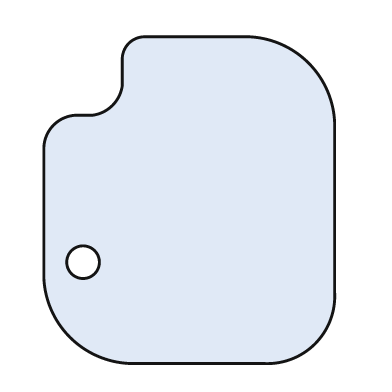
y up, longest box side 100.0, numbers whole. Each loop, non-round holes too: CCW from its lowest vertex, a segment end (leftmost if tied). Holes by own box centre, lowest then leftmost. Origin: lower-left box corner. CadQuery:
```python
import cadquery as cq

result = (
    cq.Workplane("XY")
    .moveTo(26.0, 0.0)
    .lineTo(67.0, 0.0)
    .threePointArc((83.0, 6.0), (89.0, 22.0))
    .lineTo(89.0, 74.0)
    .threePointArc((81.0, 92.0), (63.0, 100.0))
    .lineTo(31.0, 100.0)
    .threePointArc((26.0, 98.0), (24.0, 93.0))
    .lineTo(24.0, 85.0)
    .threePointArc((21.0, 79.0), (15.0, 76.0))
    .lineTo(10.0, 76.0)
    .threePointArc((3.0, 73.0), (0.0, 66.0))
    .lineTo(0.0, 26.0)
    .threePointArc((8.0, 8.0), (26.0, 0.0))
    .close()
    .moveTo(12.0, 31.0)
    .circle(5.0)
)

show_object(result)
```